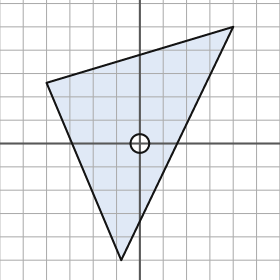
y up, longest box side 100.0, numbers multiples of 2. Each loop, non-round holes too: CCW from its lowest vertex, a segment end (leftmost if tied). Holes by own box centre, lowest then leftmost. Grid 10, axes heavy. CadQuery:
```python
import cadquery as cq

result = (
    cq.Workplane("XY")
    .moveTo(-8.0, -50.0)
    .lineTo(40.0, 50.0)
    .lineTo(-40.0, 26.0)
    .close()
    .moveTo(0.0, 0.0)
    .circle(4.0)
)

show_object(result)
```